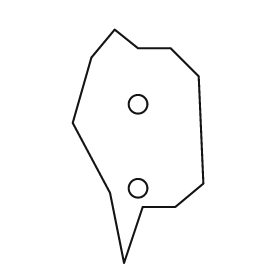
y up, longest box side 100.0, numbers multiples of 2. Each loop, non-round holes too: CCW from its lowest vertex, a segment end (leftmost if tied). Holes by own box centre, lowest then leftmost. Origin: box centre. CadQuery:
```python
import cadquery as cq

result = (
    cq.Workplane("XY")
    .moveTo(-6.0, -50.0)
    .lineTo(2.0, -26.0)
    .lineTo(16.0, -26.0)
    .lineTo(28.0, -16.0)
    .lineTo(26.0, 30.0)
    .lineTo(14.0, 42.0)
    .lineTo(0.0, 42.0)
    .lineTo(-10.0, 50.0)
    .lineTo(-20.0, 38.0)
    .lineTo(-28.0, 10.0)
    .lineTo(-12.0, -20.0)
    .close()
    .moveTo(0.0, -18.0)
    .circle(4.0)
    .moveTo(0.0, 18.0)
    .circle(4.0)
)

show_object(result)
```